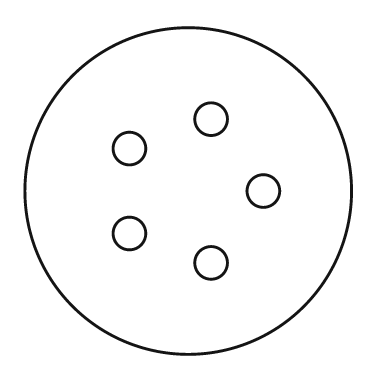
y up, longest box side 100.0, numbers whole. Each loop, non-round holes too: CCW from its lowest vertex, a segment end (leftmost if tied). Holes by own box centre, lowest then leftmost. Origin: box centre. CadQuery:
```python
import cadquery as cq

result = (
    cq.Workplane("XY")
    .moveTo(0.0, 0.0)
    .circle(50.0)
    .moveTo(7.0, -22.0)
    .circle(5.0)
    .moveTo(-18.0, -13.0)
    .circle(5.0)
    .moveTo(23.0, 0.0)
    .circle(5.0)
    .moveTo(-18.0, 13.0)
    .circle(5.0)
    .moveTo(7.0, 22.0)
    .circle(5.0)
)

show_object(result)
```